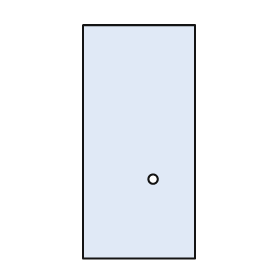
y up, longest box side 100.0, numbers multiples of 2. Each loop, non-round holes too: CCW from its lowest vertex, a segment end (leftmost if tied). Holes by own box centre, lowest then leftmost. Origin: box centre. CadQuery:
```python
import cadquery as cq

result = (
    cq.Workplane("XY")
    .moveTo(-24.0, -50.0)
    .lineTo(24.0, -50.0)
    .lineTo(24.0, 50.0)
    .lineTo(-24.0, 50.0)
    .close()
    .moveTo(6.0, -16.0)
    .circle(2.0)
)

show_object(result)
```